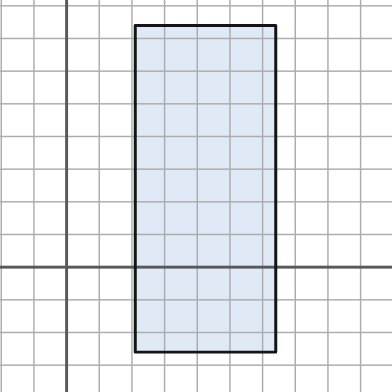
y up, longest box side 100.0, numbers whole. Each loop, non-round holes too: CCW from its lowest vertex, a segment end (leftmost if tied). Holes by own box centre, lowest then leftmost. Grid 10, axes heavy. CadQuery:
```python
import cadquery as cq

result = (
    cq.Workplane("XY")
    .moveTo(21.0, -26.0)
    .lineTo(64.0, -26.0)
    .lineTo(64.0, 74.0)
    .lineTo(21.0, 74.0)
    .close()
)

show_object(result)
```